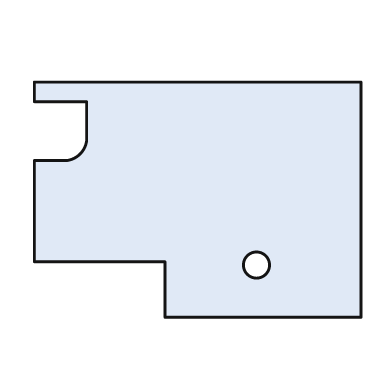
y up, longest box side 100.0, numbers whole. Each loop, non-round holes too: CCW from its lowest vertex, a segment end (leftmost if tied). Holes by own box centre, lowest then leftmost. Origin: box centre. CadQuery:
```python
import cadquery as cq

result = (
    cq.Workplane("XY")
    .moveTo(-10.0, -36.0)
    .lineTo(50.0, -36.0)
    .lineTo(50.0, 36.0)
    .lineTo(-50.0, 36.0)
    .lineTo(-50.0, 30.0)
    .lineTo(-34.0, 30.0)
    .lineTo(-34.0, 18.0)
    .threePointArc((-36.0, 14.0), (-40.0, 12.0))
    .lineTo(-50.0, 12.0)
    .lineTo(-50.0, -19.0)
    .lineTo(-10.0, -19.0)
    .close()
    .moveTo(18.0, -20.0)
    .circle(4.0)
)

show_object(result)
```